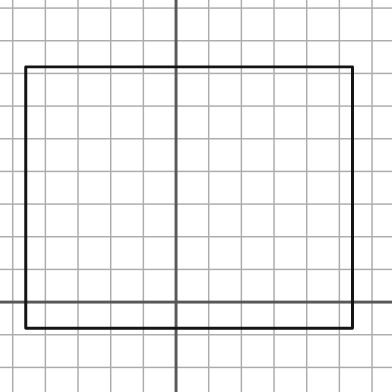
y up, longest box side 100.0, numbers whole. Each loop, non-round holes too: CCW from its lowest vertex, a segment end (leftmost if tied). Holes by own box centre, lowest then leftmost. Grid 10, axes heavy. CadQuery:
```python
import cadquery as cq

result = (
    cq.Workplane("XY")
    .moveTo(-46.0, -8.0)
    .lineTo(54.0, -8.0)
    .lineTo(54.0, 72.0)
    .lineTo(-46.0, 72.0)
    .close()
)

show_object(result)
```